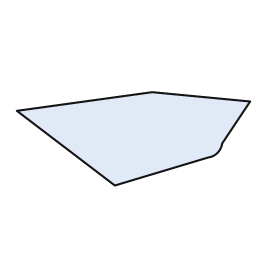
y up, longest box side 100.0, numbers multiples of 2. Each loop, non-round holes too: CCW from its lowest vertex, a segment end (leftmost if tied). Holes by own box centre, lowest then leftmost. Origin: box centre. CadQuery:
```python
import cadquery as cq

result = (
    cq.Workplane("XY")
    .moveTo(-8.0, -20.0)
    .lineTo(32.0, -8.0)
    .threePointArc((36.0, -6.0), (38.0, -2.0))
    .lineTo(50.0, 16.0)
    .lineTo(8.0, 20.0)
    .lineTo(-50.0, 12.0)
    .close()
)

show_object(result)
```